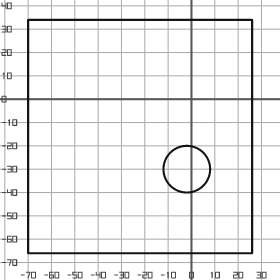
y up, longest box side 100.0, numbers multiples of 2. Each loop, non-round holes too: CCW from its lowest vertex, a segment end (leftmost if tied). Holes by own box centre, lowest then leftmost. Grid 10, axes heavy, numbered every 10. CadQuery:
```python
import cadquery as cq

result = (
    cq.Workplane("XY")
    .moveTo(-70.0, -66.0)
    .lineTo(26.0, -66.0)
    .lineTo(26.0, 34.0)
    .lineTo(-70.0, 34.0)
    .close()
    .moveTo(-2.0, -30.0)
    .circle(10.0)
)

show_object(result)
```